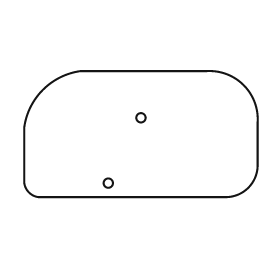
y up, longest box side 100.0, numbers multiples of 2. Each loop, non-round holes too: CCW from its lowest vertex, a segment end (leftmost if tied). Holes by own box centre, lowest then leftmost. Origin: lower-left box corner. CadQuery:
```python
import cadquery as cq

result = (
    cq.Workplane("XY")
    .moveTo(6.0, 0.0)
    .lineTo(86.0, 0.0)
    .threePointArc((96.0, 4.0), (100.0, 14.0))
    .lineTo(100.0, 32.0)
    .threePointArc((94.0, 48.0), (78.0, 54.0))
    .lineTo(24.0, 54.0)
    .threePointArc((8.0, 46.0), (0.0, 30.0))
    .lineTo(0.0, 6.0)
    .threePointArc((2.0, 2.0), (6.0, 0.0))
    .close()
    .moveTo(36.0, 6.0)
    .circle(2.0)
    .moveTo(50.0, 34.0)
    .circle(2.0)
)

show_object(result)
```